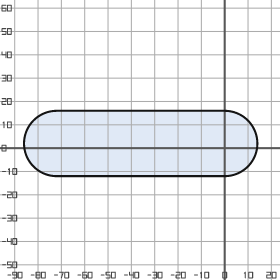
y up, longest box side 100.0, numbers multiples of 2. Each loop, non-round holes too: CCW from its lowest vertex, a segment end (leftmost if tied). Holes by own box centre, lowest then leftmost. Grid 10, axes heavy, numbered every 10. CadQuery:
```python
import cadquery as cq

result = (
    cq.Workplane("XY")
    .moveTo(-72.0, -12.0)
    .lineTo(0.0, -12.0)
    .threePointArc((14.0, 2.0), (0.0, 16.0))
    .lineTo(-72.0, 16.0)
    .threePointArc((-86.0, 2.0), (-72.0, -12.0))
    .close()
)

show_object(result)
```